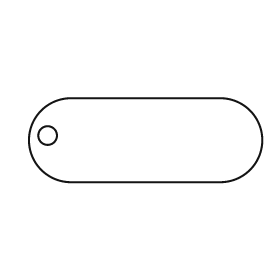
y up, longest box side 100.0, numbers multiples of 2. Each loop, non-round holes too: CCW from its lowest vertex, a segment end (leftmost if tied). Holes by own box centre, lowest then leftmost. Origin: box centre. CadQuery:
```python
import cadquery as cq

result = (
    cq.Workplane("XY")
    .moveTo(-32.0, -18.0)
    .lineTo(32.0, -18.0)
    .threePointArc((50.0, 0.0), (32.0, 18.0))
    .lineTo(-32.0, 18.0)
    .threePointArc((-50.0, 0.0), (-32.0, -18.0))
    .close()
    .moveTo(-42.0, 2.0)
    .circle(4.0)
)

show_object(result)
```